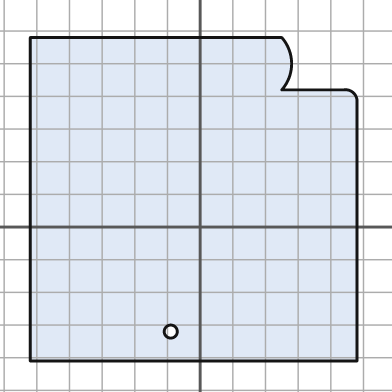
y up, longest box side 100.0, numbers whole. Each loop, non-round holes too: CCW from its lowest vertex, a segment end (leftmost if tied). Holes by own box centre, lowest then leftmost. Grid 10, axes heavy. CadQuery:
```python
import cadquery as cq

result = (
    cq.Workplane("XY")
    .moveTo(-52.0, -41.0)
    .lineTo(48.0, -41.0)
    .lineTo(48.0, 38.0)
    .threePointArc((47.0, 41.0), (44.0, 42.0))
    .lineTo(25.0, 42.0)
    .threePointArc((28.0, 50.0), (25.0, 58.0))
    .lineTo(-52.0, 58.0)
    .close()
    .moveTo(-9.0, -32.0)
    .circle(2.0)
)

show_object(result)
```